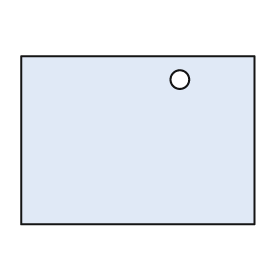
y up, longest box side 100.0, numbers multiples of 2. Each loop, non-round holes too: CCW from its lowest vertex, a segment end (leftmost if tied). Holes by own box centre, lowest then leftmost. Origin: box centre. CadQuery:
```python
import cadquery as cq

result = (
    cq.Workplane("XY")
    .moveTo(-50.0, -36.0)
    .lineTo(50.0, -36.0)
    .lineTo(50.0, 36.0)
    .lineTo(-50.0, 36.0)
    .close()
    .moveTo(18.0, 26.0)
    .circle(4.0)
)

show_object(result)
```